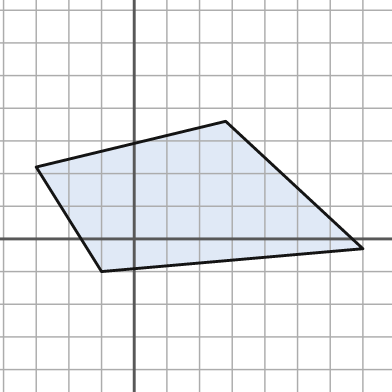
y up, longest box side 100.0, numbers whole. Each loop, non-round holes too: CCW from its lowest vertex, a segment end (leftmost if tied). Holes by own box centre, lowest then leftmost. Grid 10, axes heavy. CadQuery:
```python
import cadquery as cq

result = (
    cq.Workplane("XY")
    .moveTo(-10.0, -10.0)
    .lineTo(70.0, -3.0)
    .lineTo(28.0, 36.0)
    .lineTo(-30.0, 22.0)
    .close()
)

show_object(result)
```